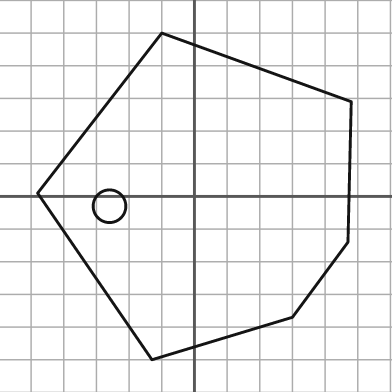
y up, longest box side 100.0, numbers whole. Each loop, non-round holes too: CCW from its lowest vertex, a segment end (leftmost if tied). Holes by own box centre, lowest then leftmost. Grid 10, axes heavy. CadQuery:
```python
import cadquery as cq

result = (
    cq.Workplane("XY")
    .moveTo(-13.0, -50.0)
    .lineTo(30.0, -37.0)
    .lineTo(47.0, -14.0)
    .lineTo(48.0, 29.0)
    .lineTo(-10.0, 50.0)
    .lineTo(-48.0, 1.0)
    .close()
    .moveTo(-26.0, -3.0)
    .circle(5.0)
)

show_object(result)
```